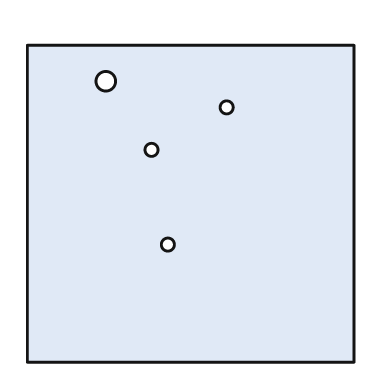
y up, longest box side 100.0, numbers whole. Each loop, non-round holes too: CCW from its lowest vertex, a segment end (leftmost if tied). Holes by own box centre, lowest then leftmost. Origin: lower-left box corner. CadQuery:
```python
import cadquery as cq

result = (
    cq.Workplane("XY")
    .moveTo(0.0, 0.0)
    .lineTo(100.0, 0.0)
    .lineTo(100.0, 97.0)
    .lineTo(0.0, 97.0)
    .close()
    .moveTo(43.0, 36.0)
    .circle(2.0)
    .moveTo(38.0, 65.0)
    .circle(2.0)
    .moveTo(61.0, 78.0)
    .circle(2.0)
    .moveTo(24.0, 86.0)
    .circle(3.0)
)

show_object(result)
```